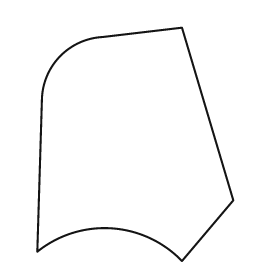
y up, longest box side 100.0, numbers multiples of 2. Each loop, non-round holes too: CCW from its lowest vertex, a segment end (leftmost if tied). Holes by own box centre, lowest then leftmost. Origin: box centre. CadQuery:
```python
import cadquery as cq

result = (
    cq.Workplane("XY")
    .moveTo(20.0, -50.0)
    .lineTo(42.0, -24.0)
    .lineTo(20.0, 50.0)
    .lineTo(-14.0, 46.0)
    .threePointArc((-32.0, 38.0), (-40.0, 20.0))
    .lineTo(-42.0, -46.0)
    .threePointArc((-10.0, -36.0), (20.0, -50.0))
    .close()
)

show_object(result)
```